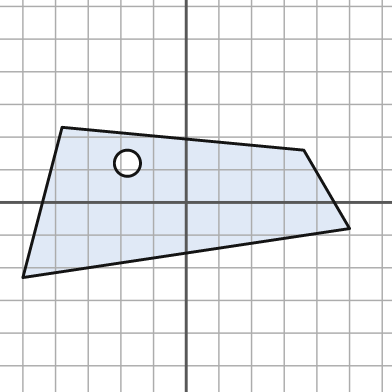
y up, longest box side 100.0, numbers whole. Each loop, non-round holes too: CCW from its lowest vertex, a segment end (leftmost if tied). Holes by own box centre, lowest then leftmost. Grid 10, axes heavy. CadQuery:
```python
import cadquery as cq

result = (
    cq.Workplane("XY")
    .moveTo(-50.0, -23.0)
    .lineTo(50.0, -8.0)
    .lineTo(36.0, 16.0)
    .lineTo(-38.0, 23.0)
    .close()
    .moveTo(-18.0, 12.0)
    .circle(4.0)
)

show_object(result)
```